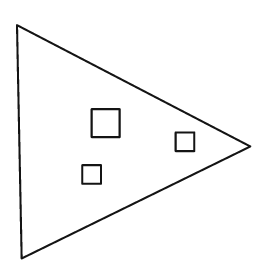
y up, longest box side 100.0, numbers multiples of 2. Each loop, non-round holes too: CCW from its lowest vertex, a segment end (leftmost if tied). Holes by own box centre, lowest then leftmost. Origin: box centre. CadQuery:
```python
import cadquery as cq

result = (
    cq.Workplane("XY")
    .moveTo(-48.0, -50.0)
    .lineTo(50.0, -2.0)
    .lineTo(-50.0, 50.0)
    .close()
    .moveTo(-22.0, -18.0)
    .lineTo(-14.0, -18.0)
    .lineTo(-14.0, -10.0)
    .lineTo(-22.0, -10.0)
    .close()
    .moveTo(18.0, -4.0)
    .lineTo(26.0, -4.0)
    .lineTo(26.0, 4.0)
    .lineTo(18.0, 4.0)
    .close()
    .moveTo(-18.0, 2.0)
    .lineTo(-6.0, 2.0)
    .lineTo(-6.0, 14.0)
    .lineTo(-18.0, 14.0)
    .close()
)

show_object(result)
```